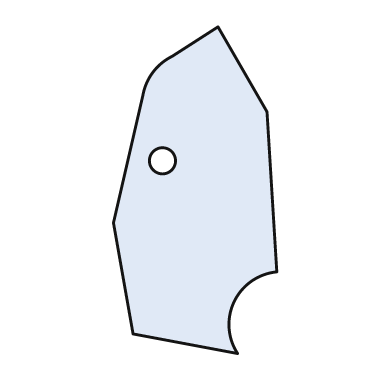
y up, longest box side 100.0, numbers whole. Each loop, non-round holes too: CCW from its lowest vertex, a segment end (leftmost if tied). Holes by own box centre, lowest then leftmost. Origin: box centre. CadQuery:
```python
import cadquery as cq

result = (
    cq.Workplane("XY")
    .moveTo(13.0, -50.0)
    .threePointArc((12.0, -34.0), (25.0, -25.0))
    .lineTo(22.0, 24.0)
    .lineTo(7.0, 50.0)
    .lineTo(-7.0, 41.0)
    .threePointArc((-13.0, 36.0), (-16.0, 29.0))
    .lineTo(-25.0, -10.0)
    .lineTo(-19.0, -44.0)
    .close()
    .moveTo(-10.0, 9.0)
    .circle(4.0)
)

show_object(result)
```